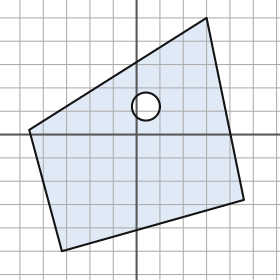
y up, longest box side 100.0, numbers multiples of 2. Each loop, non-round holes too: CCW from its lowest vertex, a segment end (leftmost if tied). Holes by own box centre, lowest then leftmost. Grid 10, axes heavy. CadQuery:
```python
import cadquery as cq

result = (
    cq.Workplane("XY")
    .moveTo(-32.0, -50.0)
    .lineTo(46.0, -28.0)
    .lineTo(30.0, 50.0)
    .lineTo(-46.0, 2.0)
    .close()
    .moveTo(4.0, 12.0)
    .circle(6.0)
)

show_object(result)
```